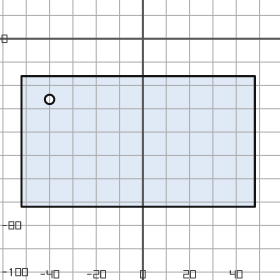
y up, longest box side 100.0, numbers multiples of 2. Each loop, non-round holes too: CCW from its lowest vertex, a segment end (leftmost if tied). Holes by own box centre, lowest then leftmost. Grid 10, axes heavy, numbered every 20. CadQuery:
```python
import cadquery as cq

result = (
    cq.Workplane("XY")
    .moveTo(-52.0, -72.0)
    .lineTo(48.0, -72.0)
    .lineTo(48.0, -16.0)
    .lineTo(-52.0, -16.0)
    .close()
    .moveTo(-40.0, -26.0)
    .circle(2.0)
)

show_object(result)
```